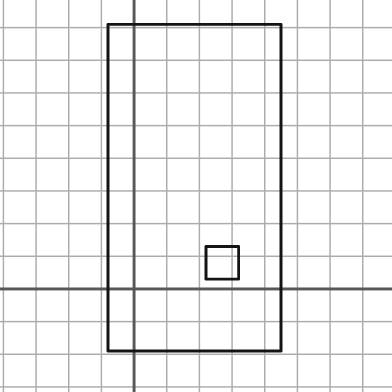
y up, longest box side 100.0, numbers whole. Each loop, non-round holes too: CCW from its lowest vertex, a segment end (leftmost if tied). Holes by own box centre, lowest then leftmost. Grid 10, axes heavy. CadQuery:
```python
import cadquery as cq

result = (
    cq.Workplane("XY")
    .moveTo(-8.0, -19.0)
    .lineTo(45.0, -19.0)
    .lineTo(45.0, 81.0)
    .lineTo(-8.0, 81.0)
    .close()
    .moveTo(22.0, 3.0)
    .lineTo(32.0, 3.0)
    .lineTo(32.0, 13.0)
    .lineTo(22.0, 13.0)
    .close()
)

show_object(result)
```